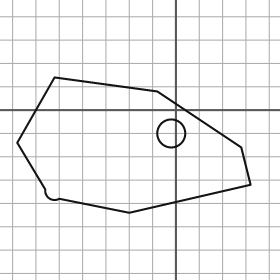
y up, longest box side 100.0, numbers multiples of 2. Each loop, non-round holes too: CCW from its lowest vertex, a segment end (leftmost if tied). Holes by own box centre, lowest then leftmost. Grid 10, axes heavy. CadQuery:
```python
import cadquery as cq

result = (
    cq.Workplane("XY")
    .moveTo(-20.0, -44.0)
    .lineTo(32.0, -32.0)
    .lineTo(28.0, -16.0)
    .lineTo(-8.0, 8.0)
    .lineTo(-52.0, 14.0)
    .lineTo(-68.0, -14.0)
    .lineTo(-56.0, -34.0)
    .threePointArc((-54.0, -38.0), (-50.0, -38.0))
    .close()
    .moveTo(-2.0, -10.0)
    .circle(6.0)
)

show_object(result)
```